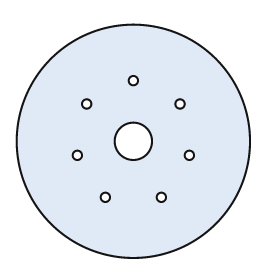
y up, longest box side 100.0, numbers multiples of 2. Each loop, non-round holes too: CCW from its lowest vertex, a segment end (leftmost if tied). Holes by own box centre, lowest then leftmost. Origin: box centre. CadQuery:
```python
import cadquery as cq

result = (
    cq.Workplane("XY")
    .moveTo(0.0, 0.0)
    .circle(50.0)
    .moveTo(-12.0, -24.0)
    .circle(2.0)
    .moveTo(12.0, -24.0)
    .circle(2.0)
    .moveTo(-24.0, -6.0)
    .circle(2.0)
    .moveTo(24.0, -6.0)
    .circle(2.0)
    .moveTo(0.0, 0.0)
    .circle(8.0)
    .moveTo(-20.0, 16.0)
    .circle(2.0)
    .moveTo(20.0, 16.0)
    .circle(2.0)
    .moveTo(0.0, 26.0)
    .circle(2.0)
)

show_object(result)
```